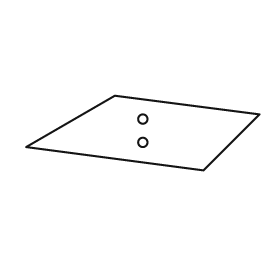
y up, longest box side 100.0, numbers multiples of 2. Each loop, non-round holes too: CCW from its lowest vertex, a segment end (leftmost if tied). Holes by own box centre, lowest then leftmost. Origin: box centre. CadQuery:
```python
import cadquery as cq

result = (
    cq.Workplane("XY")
    .moveTo(26.0, -16.0)
    .lineTo(50.0, 8.0)
    .lineTo(-12.0, 16.0)
    .lineTo(-50.0, -6.0)
    .close()
    .moveTo(0.0, -4.0)
    .circle(2.0)
    .moveTo(0.0, 6.0)
    .circle(2.0)
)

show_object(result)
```